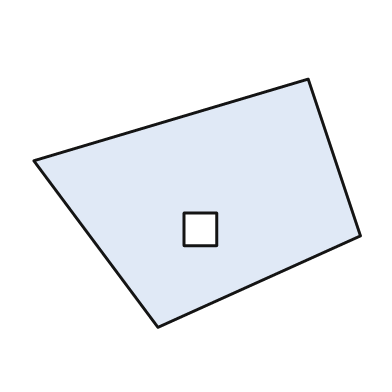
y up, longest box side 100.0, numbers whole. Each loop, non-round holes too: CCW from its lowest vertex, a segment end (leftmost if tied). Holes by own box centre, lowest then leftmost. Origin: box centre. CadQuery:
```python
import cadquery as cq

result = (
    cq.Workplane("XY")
    .moveTo(-12.0, -38.0)
    .lineTo(50.0, -10.0)
    .lineTo(34.0, 38.0)
    .lineTo(-50.0, 13.0)
    .close()
    .moveTo(-4.0, -13.0)
    .lineTo(6.0, -13.0)
    .lineTo(6.0, -3.0)
    .lineTo(-4.0, -3.0)
    .close()
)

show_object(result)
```